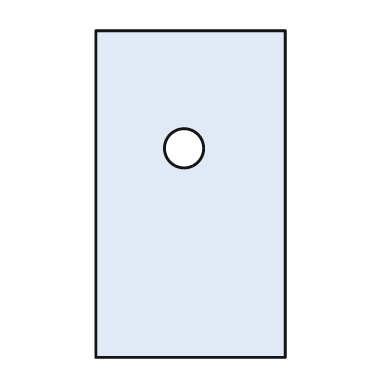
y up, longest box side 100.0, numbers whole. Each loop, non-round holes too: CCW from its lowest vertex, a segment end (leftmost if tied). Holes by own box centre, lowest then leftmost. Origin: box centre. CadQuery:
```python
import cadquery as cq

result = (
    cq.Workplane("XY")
    .moveTo(-29.0, -50.0)
    .lineTo(29.0, -50.0)
    .lineTo(29.0, 50.0)
    .lineTo(-29.0, 50.0)
    .close()
    .moveTo(-2.0, 14.0)
    .circle(6.0)
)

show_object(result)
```